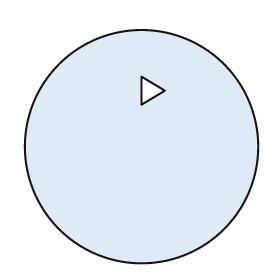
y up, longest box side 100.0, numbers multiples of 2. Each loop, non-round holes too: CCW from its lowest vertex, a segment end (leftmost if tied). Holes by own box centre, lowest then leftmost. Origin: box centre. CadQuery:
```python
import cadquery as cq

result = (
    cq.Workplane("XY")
    .moveTo(0.0, 0.0)
    .circle(50.0)
    .moveTo(0.0, 18.0)
    .lineTo(10.0, 24.0)
    .lineTo(0.0, 30.0)
    .close()
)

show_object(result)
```